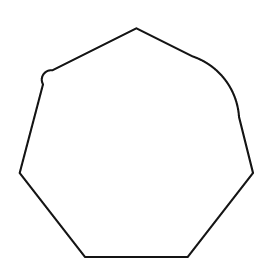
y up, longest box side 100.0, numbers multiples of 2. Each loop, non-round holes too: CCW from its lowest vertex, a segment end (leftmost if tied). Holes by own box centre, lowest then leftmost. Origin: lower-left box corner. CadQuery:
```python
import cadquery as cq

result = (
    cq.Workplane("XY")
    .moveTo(28.0, 0.0)
    .lineTo(72.0, 0.0)
    .lineTo(100.0, 36.0)
    .lineTo(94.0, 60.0)
    .threePointArc((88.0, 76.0), (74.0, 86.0))
    .lineTo(50.0, 98.0)
    .lineTo(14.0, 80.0)
    .threePointArc((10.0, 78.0), (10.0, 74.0))
    .lineTo(0.0, 36.0)
    .close()
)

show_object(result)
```